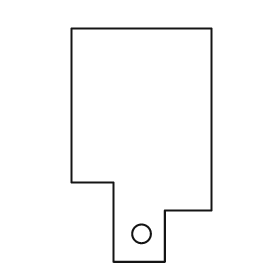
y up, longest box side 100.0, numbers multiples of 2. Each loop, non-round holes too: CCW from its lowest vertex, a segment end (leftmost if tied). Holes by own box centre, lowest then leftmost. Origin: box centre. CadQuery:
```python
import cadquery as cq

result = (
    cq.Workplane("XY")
    .moveTo(-12.0, -50.0)
    .lineTo(10.0, -50.0)
    .lineTo(10.0, -28.0)
    .lineTo(30.0, -28.0)
    .lineTo(30.0, 50.0)
    .lineTo(-30.0, 50.0)
    .lineTo(-30.0, -16.0)
    .lineTo(-12.0, -16.0)
    .close()
    .moveTo(0.0, -38.0)
    .circle(4.0)
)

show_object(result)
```